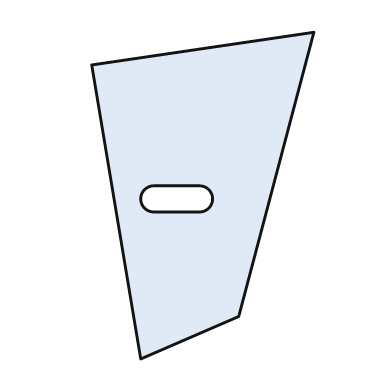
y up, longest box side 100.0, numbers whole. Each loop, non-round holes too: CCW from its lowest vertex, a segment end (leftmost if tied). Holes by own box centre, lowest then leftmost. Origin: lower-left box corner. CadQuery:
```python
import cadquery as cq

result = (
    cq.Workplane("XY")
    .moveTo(15.0, 0.0)
    .lineTo(45.0, 13.0)
    .lineTo(68.0, 100.0)
    .lineTo(0.0, 90.0)
    .close()
    .moveTo(19.0, 45.0)
    .lineTo(33.0, 45.0)
    .threePointArc((37.0, 49.0), (33.0, 53.0))
    .lineTo(19.0, 53.0)
    .threePointArc((15.0, 49.0), (19.0, 45.0))
    .close()
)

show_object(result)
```